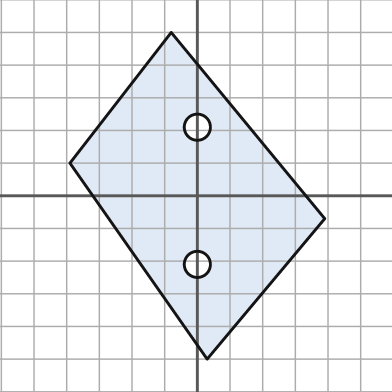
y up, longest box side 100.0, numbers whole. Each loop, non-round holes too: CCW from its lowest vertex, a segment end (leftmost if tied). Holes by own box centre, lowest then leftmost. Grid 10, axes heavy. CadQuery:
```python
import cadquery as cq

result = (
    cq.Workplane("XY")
    .moveTo(3.0, -50.0)
    .lineTo(39.0, -7.0)
    .lineTo(-8.0, 50.0)
    .lineTo(-39.0, 10.0)
    .close()
    .moveTo(0.0, -21.0)
    .circle(4.0)
    .moveTo(0.0, 21.0)
    .circle(4.0)
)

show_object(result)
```